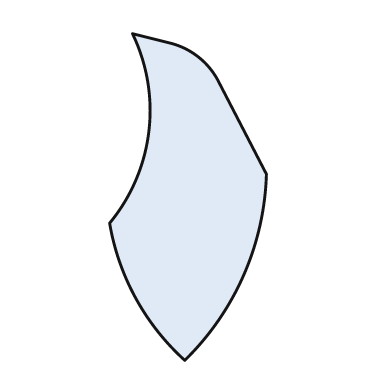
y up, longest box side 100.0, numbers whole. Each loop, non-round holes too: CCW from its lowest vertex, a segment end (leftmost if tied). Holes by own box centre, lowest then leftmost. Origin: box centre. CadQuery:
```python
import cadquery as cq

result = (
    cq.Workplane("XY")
    .moveTo(-1.0, -50.0)
    .threePointArc((17.0, -24.0), (24.0, 7.0))
    .lineTo(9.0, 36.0)
    .threePointArc((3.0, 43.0), (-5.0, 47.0))
    .lineTo(-17.0, 50.0)
    .threePointArc((-12.0, 20.0), (-24.0, -8.0))
    .threePointArc((-16.0, -31.0), (-1.0, -50.0))
    .close()
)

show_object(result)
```